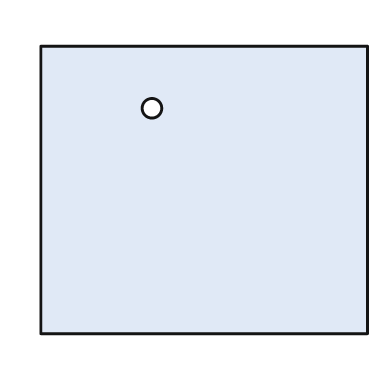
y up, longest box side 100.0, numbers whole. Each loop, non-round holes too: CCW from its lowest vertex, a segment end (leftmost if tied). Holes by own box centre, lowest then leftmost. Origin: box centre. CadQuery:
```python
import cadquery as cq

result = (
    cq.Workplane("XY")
    .moveTo(-50.0, -44.0)
    .lineTo(50.0, -44.0)
    .lineTo(50.0, 44.0)
    .lineTo(-50.0, 44.0)
    .close()
    .moveTo(-16.0, 25.0)
    .circle(3.0)
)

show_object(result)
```